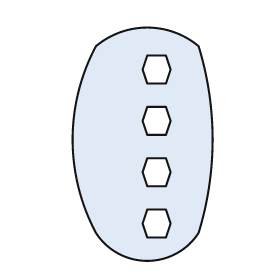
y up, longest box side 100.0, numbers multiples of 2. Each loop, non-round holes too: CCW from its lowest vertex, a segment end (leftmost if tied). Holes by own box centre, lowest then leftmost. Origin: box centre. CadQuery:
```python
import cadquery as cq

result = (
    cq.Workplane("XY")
    .moveTo(-20.0, -38.0)
    .threePointArc((2.0, -50.0), (24.0, -38.0))
    .threePointArc((30.0, 2.0), (24.0, 42.0))
    .threePointArc((2.0, 50.0), (-20.0, 42.0))
    .threePointArc((-30.0, 2.0), (-20.0, -38.0))
    .close()
    .moveTo(2.0, -40.0)
    .lineTo(10.0, -40.0)
    .lineTo(12.0, -34.0)
    .lineTo(10.0, -28.0)
    .lineTo(2.0, -28.0)
    .lineTo(0.0, -34.0)
    .close()
    .moveTo(2.0, -18.0)
    .lineTo(10.0, -18.0)
    .lineTo(12.0, -12.0)
    .lineTo(10.0, -6.0)
    .lineTo(2.0, -6.0)
    .lineTo(0.0, -12.0)
    .close()
    .moveTo(2.0, 4.0)
    .lineTo(10.0, 4.0)
    .lineTo(12.0, 10.0)
    .lineTo(10.0, 16.0)
    .lineTo(2.0, 16.0)
    .lineTo(0.0, 10.0)
    .close()
    .moveTo(2.0, 26.0)
    .lineTo(10.0, 26.0)
    .lineTo(12.0, 32.0)
    .lineTo(10.0, 38.0)
    .lineTo(2.0, 38.0)
    .lineTo(0.0, 32.0)
    .close()
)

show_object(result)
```